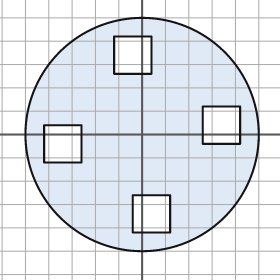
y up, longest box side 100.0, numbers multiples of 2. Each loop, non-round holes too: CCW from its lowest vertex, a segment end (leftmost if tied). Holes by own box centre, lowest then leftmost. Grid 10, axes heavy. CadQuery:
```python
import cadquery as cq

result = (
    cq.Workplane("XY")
    .moveTo(0.0, 0.0)
    .circle(50.0)
    .moveTo(-4.0, -42.0)
    .lineTo(12.0, -42.0)
    .lineTo(12.0, -26.0)
    .lineTo(-4.0, -26.0)
    .close()
    .moveTo(-42.0, -12.0)
    .lineTo(-26.0, -12.0)
    .lineTo(-26.0, 4.0)
    .lineTo(-42.0, 4.0)
    .close()
    .moveTo(26.0, -4.0)
    .lineTo(42.0, -4.0)
    .lineTo(42.0, 12.0)
    .lineTo(26.0, 12.0)
    .close()
    .moveTo(-12.0, 26.0)
    .lineTo(4.0, 26.0)
    .lineTo(4.0, 42.0)
    .lineTo(-12.0, 42.0)
    .close()
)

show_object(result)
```